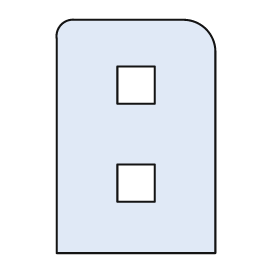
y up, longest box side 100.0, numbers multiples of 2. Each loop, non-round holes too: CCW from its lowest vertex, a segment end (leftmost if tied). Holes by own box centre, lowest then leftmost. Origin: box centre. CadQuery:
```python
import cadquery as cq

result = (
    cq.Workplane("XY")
    .moveTo(-34.0, -50.0)
    .lineTo(34.0, -50.0)
    .lineTo(34.0, 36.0)
    .threePointArc((30.0, 46.0), (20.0, 50.0))
    .lineTo(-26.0, 50.0)
    .threePointArc((-32.0, 48.0), (-34.0, 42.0))
    .close()
    .moveTo(-8.0, -28.0)
    .lineTo(8.0, -28.0)
    .lineTo(8.0, -12.0)
    .lineTo(-8.0, -12.0)
    .close()
    .moveTo(-8.0, 14.0)
    .lineTo(8.0, 14.0)
    .lineTo(8.0, 30.0)
    .lineTo(-8.0, 30.0)
    .close()
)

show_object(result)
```